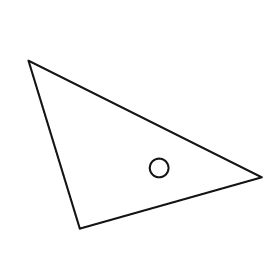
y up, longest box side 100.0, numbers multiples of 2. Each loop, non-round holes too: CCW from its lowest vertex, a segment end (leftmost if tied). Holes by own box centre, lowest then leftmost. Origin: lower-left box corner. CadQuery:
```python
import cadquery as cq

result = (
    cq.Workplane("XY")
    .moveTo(22.0, 0.0)
    .lineTo(100.0, 22.0)
    .lineTo(0.0, 72.0)
    .close()
    .moveTo(56.0, 26.0)
    .circle(4.0)
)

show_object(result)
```